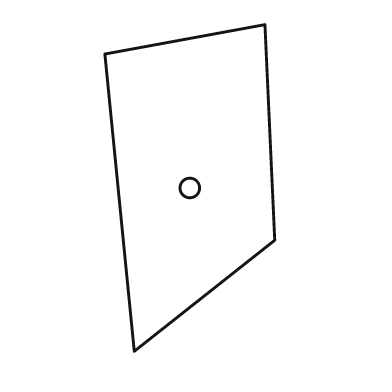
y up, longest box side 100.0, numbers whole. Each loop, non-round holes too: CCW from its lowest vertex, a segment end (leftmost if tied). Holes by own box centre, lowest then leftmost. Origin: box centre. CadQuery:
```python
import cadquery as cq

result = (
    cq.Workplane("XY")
    .moveTo(-17.0, -50.0)
    .lineTo(26.0, -16.0)
    .lineTo(23.0, 50.0)
    .lineTo(-26.0, 41.0)
    .close()
    .moveTo(0.0, 0.0)
    .circle(3.0)
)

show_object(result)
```